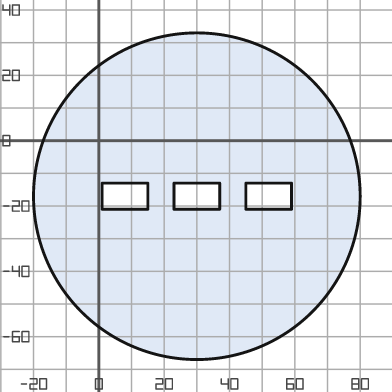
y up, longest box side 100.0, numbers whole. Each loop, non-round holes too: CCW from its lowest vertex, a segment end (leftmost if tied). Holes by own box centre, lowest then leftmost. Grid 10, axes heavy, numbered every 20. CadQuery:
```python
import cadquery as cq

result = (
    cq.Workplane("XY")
    .moveTo(30.0, -17.0)
    .circle(50.0)
    .moveTo(1.0, -21.0)
    .lineTo(15.0, -21.0)
    .lineTo(15.0, -13.0)
    .lineTo(1.0, -13.0)
    .close()
    .moveTo(23.0, -21.0)
    .lineTo(37.0, -21.0)
    .lineTo(37.0, -13.0)
    .lineTo(23.0, -13.0)
    .close()
    .moveTo(45.0, -21.0)
    .lineTo(59.0, -21.0)
    .lineTo(59.0, -13.0)
    .lineTo(45.0, -13.0)
    .close()
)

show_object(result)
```